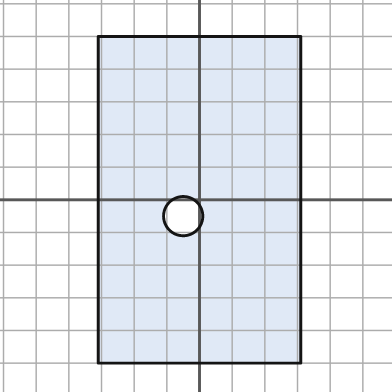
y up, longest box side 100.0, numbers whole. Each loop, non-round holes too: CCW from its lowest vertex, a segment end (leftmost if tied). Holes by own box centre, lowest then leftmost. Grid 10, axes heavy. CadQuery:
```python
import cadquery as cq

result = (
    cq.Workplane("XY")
    .moveTo(-31.0, -50.0)
    .lineTo(31.0, -50.0)
    .lineTo(31.0, 50.0)
    .lineTo(-31.0, 50.0)
    .close()
    .moveTo(-5.0, -5.0)
    .circle(6.0)
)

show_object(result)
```